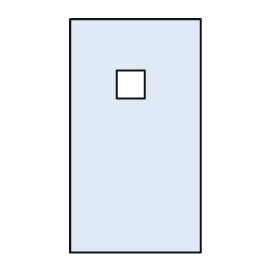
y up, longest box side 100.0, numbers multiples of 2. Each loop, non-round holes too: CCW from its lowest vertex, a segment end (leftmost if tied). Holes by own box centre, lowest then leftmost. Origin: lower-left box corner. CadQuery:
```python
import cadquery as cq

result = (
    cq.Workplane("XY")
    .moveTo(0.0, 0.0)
    .lineTo(56.0, 0.0)
    .lineTo(56.0, 100.0)
    .lineTo(0.0, 100.0)
    .close()
    .moveTo(20.0, 66.0)
    .lineTo(32.0, 66.0)
    .lineTo(32.0, 78.0)
    .lineTo(20.0, 78.0)
    .close()
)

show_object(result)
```